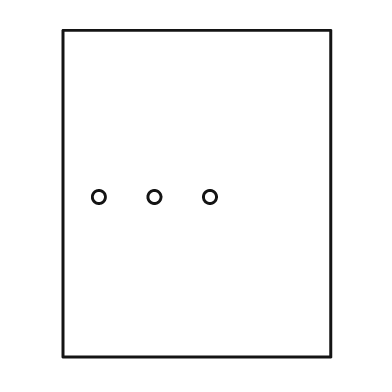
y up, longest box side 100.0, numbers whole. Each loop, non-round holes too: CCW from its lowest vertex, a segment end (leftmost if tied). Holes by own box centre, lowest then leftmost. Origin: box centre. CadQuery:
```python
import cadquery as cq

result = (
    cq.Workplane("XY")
    .moveTo(-41.0, -50.0)
    .lineTo(41.0, -50.0)
    .lineTo(41.0, 50.0)
    .lineTo(-41.0, 50.0)
    .close()
    .moveTo(-30.0, -1.0)
    .circle(2.0)
    .moveTo(-13.0, -1.0)
    .circle(2.0)
    .moveTo(4.0, -1.0)
    .circle(2.0)
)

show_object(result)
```